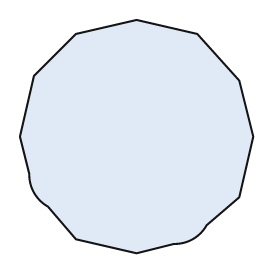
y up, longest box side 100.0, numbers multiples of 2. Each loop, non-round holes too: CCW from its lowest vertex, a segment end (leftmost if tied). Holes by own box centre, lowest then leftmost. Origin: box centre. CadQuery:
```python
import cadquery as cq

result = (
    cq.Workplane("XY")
    .moveTo(0.0, -50.0)
    .lineTo(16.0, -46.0)
    .threePointArc((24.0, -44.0), (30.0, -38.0))
    .lineTo(44.0, -26.0)
    .lineTo(50.0, 0.0)
    .lineTo(44.0, 24.0)
    .lineTo(26.0, 44.0)
    .lineTo(0.0, 50.0)
    .lineTo(-26.0, 44.0)
    .lineTo(-44.0, 26.0)
    .lineTo(-50.0, 0.0)
    .lineTo(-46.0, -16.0)
    .threePointArc((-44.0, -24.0), (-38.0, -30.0))
    .lineTo(-26.0, -44.0)
    .close()
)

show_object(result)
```